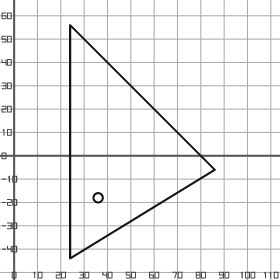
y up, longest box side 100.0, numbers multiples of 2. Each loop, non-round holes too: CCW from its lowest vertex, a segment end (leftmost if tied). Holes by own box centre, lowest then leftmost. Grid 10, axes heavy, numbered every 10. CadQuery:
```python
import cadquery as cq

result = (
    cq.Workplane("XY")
    .moveTo(24.0, -44.0)
    .lineTo(86.0, -6.0)
    .lineTo(24.0, 56.0)
    .close()
    .moveTo(36.0, -18.0)
    .circle(2.0)
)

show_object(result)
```